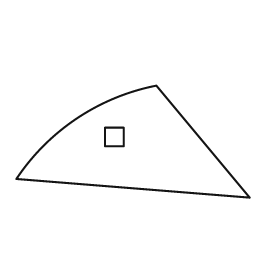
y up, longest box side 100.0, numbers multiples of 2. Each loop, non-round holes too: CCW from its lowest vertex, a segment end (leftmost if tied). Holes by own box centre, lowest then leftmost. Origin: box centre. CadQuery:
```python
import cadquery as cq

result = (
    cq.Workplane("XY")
    .moveTo(50.0, -24.0)
    .lineTo(10.0, 24.0)
    .threePointArc((-24.0, 10.0), (-50.0, -16.0))
    .close()
    .moveTo(-12.0, -2.0)
    .lineTo(-4.0, -2.0)
    .lineTo(-4.0, 6.0)
    .lineTo(-12.0, 6.0)
    .close()
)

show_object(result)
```